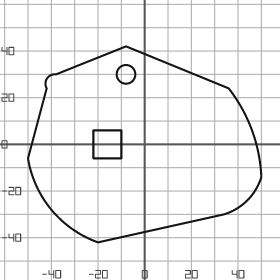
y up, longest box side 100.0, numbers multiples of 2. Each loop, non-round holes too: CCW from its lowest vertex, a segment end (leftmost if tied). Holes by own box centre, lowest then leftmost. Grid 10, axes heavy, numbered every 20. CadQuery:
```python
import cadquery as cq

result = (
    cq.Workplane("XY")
    .moveTo(-20.0, -42.0)
    .lineTo(34.0, -30.0)
    .threePointArc((44.0, -24.0), (50.0, -14.0))
    .threePointArc((46.0, 6.0), (36.0, 24.0))
    .lineTo(-8.0, 42.0)
    .lineTo(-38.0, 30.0)
    .threePointArc((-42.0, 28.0), (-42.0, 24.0))
    .lineTo(-50.0, -6.0)
    .threePointArc((-40.0, -28.0), (-20.0, -42.0))
    .close()
    .moveTo(-22.0, -6.0)
    .lineTo(-10.0, -6.0)
    .lineTo(-10.0, 6.0)
    .lineTo(-22.0, 6.0)
    .close()
    .moveTo(-8.0, 30.0)
    .circle(4.0)
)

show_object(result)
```